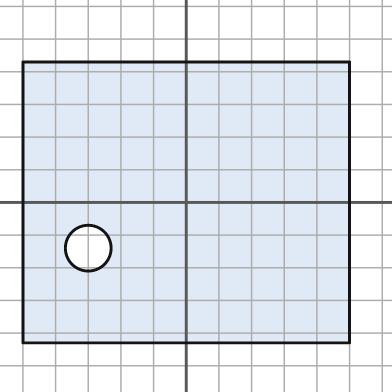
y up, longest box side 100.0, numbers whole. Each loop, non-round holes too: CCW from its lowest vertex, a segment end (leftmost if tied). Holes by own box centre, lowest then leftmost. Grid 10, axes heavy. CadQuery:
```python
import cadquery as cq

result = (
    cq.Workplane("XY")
    .moveTo(-50.0, -43.0)
    .lineTo(50.0, -43.0)
    .lineTo(50.0, 43.0)
    .lineTo(-50.0, 43.0)
    .close()
    .moveTo(-30.0, -14.0)
    .circle(7.0)
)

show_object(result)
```